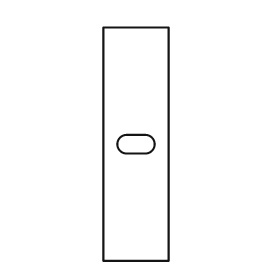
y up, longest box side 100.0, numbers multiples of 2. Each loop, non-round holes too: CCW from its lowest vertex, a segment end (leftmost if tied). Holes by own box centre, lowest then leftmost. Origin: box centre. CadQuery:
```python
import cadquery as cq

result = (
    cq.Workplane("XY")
    .moveTo(-14.0, -50.0)
    .lineTo(14.0, -50.0)
    .lineTo(14.0, 50.0)
    .lineTo(-14.0, 50.0)
    .close()
    .moveTo(-4.0, -4.0)
    .lineTo(4.0, -4.0)
    .threePointArc((8.0, 0.0), (4.0, 4.0))
    .lineTo(-4.0, 4.0)
    .threePointArc((-8.0, 0.0), (-4.0, -4.0))
    .close()
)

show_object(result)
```